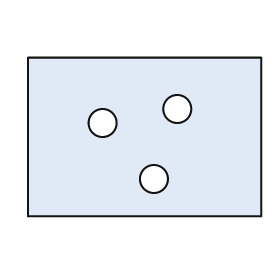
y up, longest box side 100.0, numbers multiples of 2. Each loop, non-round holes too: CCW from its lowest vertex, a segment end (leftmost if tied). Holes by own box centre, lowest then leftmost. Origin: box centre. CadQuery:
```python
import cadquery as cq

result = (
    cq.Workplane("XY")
    .moveTo(-50.0, -34.0)
    .lineTo(50.0, -34.0)
    .lineTo(50.0, 34.0)
    .lineTo(-50.0, 34.0)
    .close()
    .moveTo(4.0, -18.0)
    .circle(6.0)
    .moveTo(-18.0, 6.0)
    .circle(6.0)
    .moveTo(14.0, 12.0)
    .circle(6.0)
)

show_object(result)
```